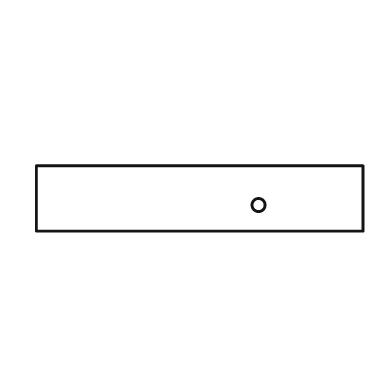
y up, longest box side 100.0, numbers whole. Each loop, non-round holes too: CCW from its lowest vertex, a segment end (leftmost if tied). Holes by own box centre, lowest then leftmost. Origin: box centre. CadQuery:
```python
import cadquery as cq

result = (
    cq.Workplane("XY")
    .moveTo(-50.0, -10.0)
    .lineTo(50.0, -10.0)
    .lineTo(50.0, 10.0)
    .lineTo(-50.0, 10.0)
    .close()
    .moveTo(18.0, -2.0)
    .circle(2.0)
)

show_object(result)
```